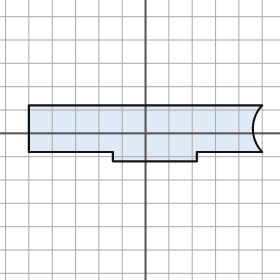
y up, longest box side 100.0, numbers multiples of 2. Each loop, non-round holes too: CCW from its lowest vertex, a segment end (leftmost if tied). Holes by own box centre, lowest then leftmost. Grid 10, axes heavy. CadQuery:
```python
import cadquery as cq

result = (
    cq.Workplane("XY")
    .moveTo(-14.0, -12.0)
    .lineTo(22.0, -12.0)
    .lineTo(22.0, -8.0)
    .lineTo(50.0, -8.0)
    .threePointArc((46.0, 2.0), (50.0, 12.0))
    .lineTo(-50.0, 12.0)
    .lineTo(-50.0, -8.0)
    .lineTo(-14.0, -8.0)
    .close()
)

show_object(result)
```